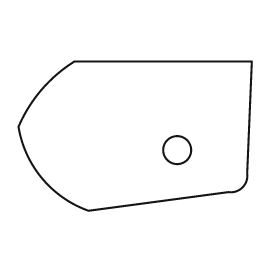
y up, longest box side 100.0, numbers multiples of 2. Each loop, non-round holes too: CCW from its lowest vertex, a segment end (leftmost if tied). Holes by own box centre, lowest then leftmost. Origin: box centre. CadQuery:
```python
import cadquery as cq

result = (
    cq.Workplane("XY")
    .moveTo(-20.0, -32.0)
    .lineTo(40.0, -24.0)
    .threePointArc((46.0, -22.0), (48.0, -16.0))
    .lineTo(50.0, 32.0)
    .lineTo(-26.0, 32.0)
    .threePointArc((-40.0, 20.0), (-50.0, 4.0))
    .threePointArc((-40.0, -18.0), (-20.0, -32.0))
    .close()
    .moveTo(18.0, -6.0)
    .circle(6.0)
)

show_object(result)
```